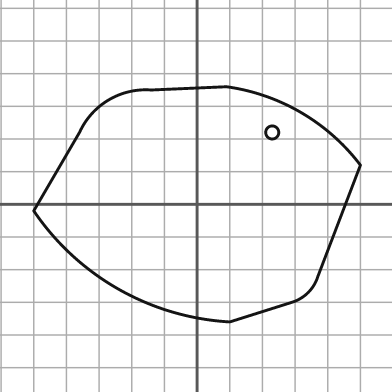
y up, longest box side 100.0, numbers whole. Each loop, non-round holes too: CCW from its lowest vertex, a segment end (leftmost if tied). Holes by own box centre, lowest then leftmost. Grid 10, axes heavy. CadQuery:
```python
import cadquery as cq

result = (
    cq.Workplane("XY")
    .moveTo(10.0, -36.0)
    .lineTo(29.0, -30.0)
    .threePointArc((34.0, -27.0), (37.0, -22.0))
    .lineTo(50.0, 12.0)
    .threePointArc((32.0, 28.0), (9.0, 36.0))
    .lineTo(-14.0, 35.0)
    .threePointArc((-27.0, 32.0), (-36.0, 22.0))
    .lineTo(-50.0, -2.0)
    .threePointArc((-24.0, -26.0), (10.0, -36.0))
    .close()
    .moveTo(23.0, 22.0)
    .circle(2.0)
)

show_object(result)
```